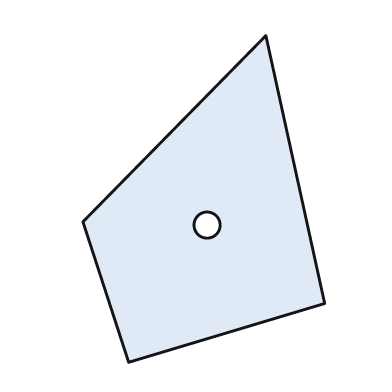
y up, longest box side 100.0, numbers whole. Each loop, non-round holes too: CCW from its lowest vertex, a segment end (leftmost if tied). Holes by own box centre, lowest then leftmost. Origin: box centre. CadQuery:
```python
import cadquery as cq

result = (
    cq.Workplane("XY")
    .moveTo(-23.0, -50.0)
    .lineTo(37.0, -32.0)
    .lineTo(19.0, 50.0)
    .lineTo(-37.0, -7.0)
    .close()
    .moveTo(1.0, -8.0)
    .circle(4.0)
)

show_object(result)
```